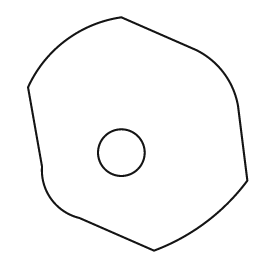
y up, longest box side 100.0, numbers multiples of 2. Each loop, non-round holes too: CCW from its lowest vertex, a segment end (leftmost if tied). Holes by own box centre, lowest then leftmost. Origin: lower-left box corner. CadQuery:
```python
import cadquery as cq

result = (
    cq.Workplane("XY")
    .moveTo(54.0, 0.0)
    .threePointArc((76.0, 12.0), (94.0, 30.0))
    .lineTo(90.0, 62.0)
    .threePointArc((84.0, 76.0), (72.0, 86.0))
    .lineTo(40.0, 100.0)
    .threePointArc((16.0, 90.0), (0.0, 70.0))
    .lineTo(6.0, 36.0)
    .threePointArc((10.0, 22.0), (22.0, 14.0))
    .close()
    .moveTo(40.0, 42.0)
    .circle(10.0)
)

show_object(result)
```